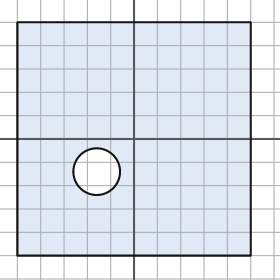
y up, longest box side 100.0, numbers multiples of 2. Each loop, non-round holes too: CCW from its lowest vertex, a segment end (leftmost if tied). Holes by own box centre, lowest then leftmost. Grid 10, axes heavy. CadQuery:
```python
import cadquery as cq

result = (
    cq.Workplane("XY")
    .moveTo(-50.0, -50.0)
    .lineTo(50.0, -50.0)
    .lineTo(50.0, 50.0)
    .lineTo(-50.0, 50.0)
    .close()
    .moveTo(-16.0, -14.0)
    .circle(10.0)
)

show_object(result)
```